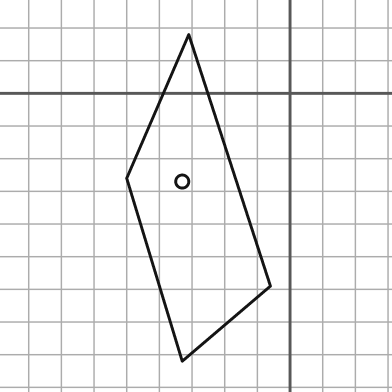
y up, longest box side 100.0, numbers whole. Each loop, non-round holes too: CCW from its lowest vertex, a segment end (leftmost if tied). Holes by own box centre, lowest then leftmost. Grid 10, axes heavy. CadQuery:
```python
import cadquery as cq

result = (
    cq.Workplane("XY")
    .moveTo(-33.0, -82.0)
    .lineTo(-6.0, -59.0)
    .lineTo(-31.0, 18.0)
    .lineTo(-50.0, -26.0)
    .close()
    .moveTo(-33.0, -27.0)
    .circle(2.0)
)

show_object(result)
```